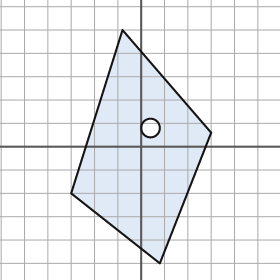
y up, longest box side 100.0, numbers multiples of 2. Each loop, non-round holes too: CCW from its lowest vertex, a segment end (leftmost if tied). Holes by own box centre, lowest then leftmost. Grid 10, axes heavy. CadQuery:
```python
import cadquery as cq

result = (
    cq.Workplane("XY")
    .moveTo(8.0, -50.0)
    .lineTo(30.0, 6.0)
    .lineTo(-8.0, 50.0)
    .lineTo(-30.0, -20.0)
    .close()
    .moveTo(4.0, 8.0)
    .circle(4.0)
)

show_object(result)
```